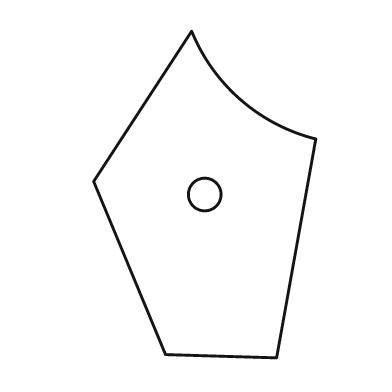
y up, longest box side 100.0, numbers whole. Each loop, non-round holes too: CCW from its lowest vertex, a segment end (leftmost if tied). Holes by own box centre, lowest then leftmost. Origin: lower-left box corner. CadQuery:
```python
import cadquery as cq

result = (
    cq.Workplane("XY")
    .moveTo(56.0, 0.0)
    .lineTo(68.0, 67.0)
    .threePointArc((45.0, 79.0), (30.0, 100.0))
    .lineTo(0.0, 54.0)
    .lineTo(22.0, 1.0)
    .close()
    .moveTo(34.0, 50.0)
    .circle(5.0)
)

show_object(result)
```